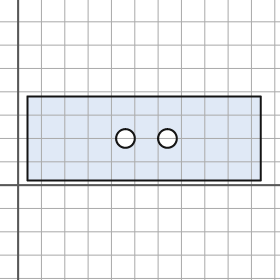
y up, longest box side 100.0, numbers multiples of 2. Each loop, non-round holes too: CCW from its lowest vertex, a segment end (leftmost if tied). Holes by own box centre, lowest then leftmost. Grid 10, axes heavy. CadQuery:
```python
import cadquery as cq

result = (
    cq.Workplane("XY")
    .moveTo(4.0, 2.0)
    .lineTo(104.0, 2.0)
    .lineTo(104.0, 38.0)
    .lineTo(4.0, 38.0)
    .close()
    .moveTo(46.0, 20.0)
    .circle(4.0)
    .moveTo(64.0, 20.0)
    .circle(4.0)
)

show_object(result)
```